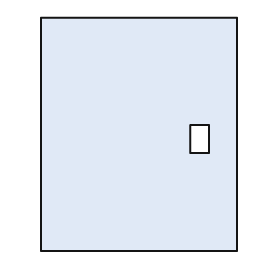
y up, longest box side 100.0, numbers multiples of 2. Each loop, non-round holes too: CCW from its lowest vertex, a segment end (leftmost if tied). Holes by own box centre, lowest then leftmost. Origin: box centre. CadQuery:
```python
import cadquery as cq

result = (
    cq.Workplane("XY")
    .moveTo(-42.0, -50.0)
    .lineTo(42.0, -50.0)
    .lineTo(42.0, 50.0)
    .lineTo(-42.0, 50.0)
    .close()
    .moveTo(22.0, -8.0)
    .lineTo(30.0, -8.0)
    .lineTo(30.0, 4.0)
    .lineTo(22.0, 4.0)
    .close()
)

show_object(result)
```